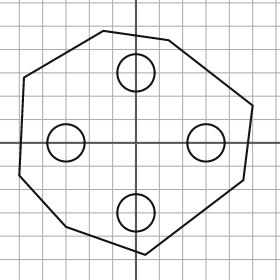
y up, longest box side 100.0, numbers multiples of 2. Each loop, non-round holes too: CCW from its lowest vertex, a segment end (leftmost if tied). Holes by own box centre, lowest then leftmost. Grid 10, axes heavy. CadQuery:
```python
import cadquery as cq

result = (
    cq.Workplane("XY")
    .moveTo(4.0, -48.0)
    .lineTo(46.0, -16.0)
    .lineTo(50.0, 16.0)
    .lineTo(14.0, 44.0)
    .lineTo(-14.0, 48.0)
    .lineTo(-48.0, 28.0)
    .lineTo(-50.0, -14.0)
    .lineTo(-30.0, -36.0)
    .close()
    .moveTo(0.0, -30.0)
    .circle(8.0)
    .moveTo(-30.0, 0.0)
    .circle(8.0)
    .moveTo(30.0, 0.0)
    .circle(8.0)
    .moveTo(0.0, 30.0)
    .circle(8.0)
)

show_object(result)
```